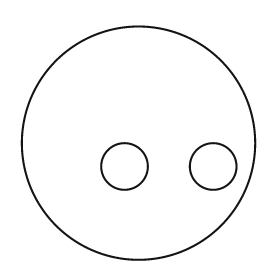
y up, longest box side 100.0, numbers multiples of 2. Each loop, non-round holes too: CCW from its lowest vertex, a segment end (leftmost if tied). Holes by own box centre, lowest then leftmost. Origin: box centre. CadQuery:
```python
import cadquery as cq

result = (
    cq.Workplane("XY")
    .moveTo(0.0, 0.0)
    .circle(50.0)
    .moveTo(-6.0, -10.0)
    .circle(10.0)
    .moveTo(32.0, -10.0)
    .circle(10.0)
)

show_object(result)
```